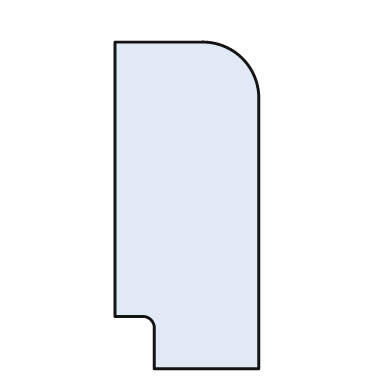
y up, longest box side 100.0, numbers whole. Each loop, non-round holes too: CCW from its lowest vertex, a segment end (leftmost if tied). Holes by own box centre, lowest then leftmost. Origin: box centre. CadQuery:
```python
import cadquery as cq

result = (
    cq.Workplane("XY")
    .moveTo(-10.0, -50.0)
    .lineTo(22.0, -50.0)
    .lineTo(22.0, 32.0)
    .threePointArc((17.0, 45.0), (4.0, 50.0))
    .lineTo(-22.0, 50.0)
    .lineTo(-22.0, -34.0)
    .lineTo(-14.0, -34.0)
    .threePointArc((-11.0, -35.0), (-10.0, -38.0))
    .close()
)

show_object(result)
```